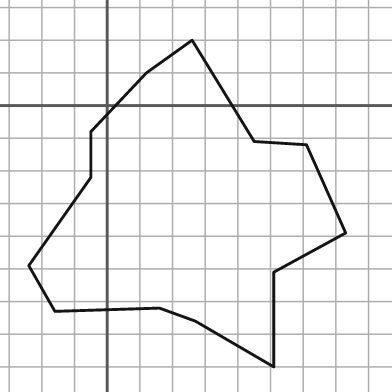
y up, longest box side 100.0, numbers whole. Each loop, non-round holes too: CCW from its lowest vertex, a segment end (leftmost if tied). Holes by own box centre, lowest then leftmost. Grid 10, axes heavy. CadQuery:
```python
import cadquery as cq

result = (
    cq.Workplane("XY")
    .moveTo(51.0, -80.0)
    .lineTo(51.0, -51.0)
    .lineTo(73.0, -39.0)
    .lineTo(61.0, -12.0)
    .lineTo(45.0, -11.0)
    .lineTo(26.0, 20.0)
    .lineTo(12.0, 10.0)
    .lineTo(-5.0, -8.0)
    .lineTo(-5.0, -22.0)
    .lineTo(-24.0, -49.0)
    .lineTo(-16.0, -63.0)
    .lineTo(16.0, -62.0)
    .lineTo(27.0, -66.0)
    .close()
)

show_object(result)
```